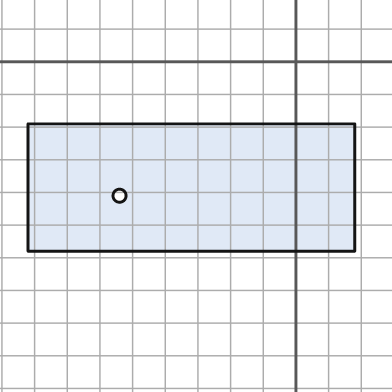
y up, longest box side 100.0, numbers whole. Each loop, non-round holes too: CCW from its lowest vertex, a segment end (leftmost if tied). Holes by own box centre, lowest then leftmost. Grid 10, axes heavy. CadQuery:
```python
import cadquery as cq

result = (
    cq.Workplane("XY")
    .moveTo(-82.0, -58.0)
    .lineTo(18.0, -58.0)
    .lineTo(18.0, -19.0)
    .lineTo(-82.0, -19.0)
    .close()
    .moveTo(-54.0, -41.0)
    .circle(2.0)
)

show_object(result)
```